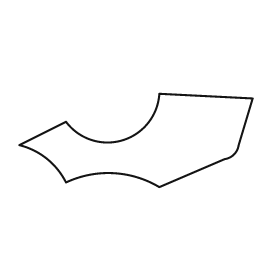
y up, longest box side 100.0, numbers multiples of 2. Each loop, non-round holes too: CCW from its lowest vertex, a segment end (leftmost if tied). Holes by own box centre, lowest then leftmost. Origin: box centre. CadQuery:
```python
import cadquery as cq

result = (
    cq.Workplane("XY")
    .moveTo(10.0, -20.0)
    .lineTo(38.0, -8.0)
    .threePointArc((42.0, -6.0), (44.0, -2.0))
    .lineTo(50.0, 18.0)
    .lineTo(10.0, 20.0)
    .threePointArc((-6.0, 0.0), (-30.0, 8.0))
    .lineTo(-50.0, -2.0)
    .threePointArc((-38.0, -8.0), (-30.0, -18.0))
    .threePointArc((-10.0, -14.0), (10.0, -20.0))
    .close()
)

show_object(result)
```